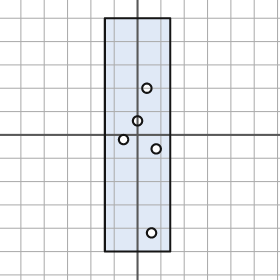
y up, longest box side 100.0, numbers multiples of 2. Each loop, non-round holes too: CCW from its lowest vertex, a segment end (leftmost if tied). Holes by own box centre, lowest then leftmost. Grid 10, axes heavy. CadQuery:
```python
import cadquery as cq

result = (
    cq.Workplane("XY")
    .moveTo(-14.0, -50.0)
    .lineTo(14.0, -50.0)
    .lineTo(14.0, 50.0)
    .lineTo(-14.0, 50.0)
    .close()
    .moveTo(6.0, -42.0)
    .circle(2.0)
    .moveTo(8.0, -6.0)
    .circle(2.0)
    .moveTo(-6.0, -2.0)
    .circle(2.0)
    .moveTo(0.0, 6.0)
    .circle(2.0)
    .moveTo(4.0, 20.0)
    .circle(2.0)
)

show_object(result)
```